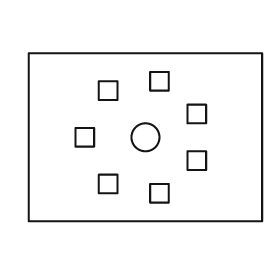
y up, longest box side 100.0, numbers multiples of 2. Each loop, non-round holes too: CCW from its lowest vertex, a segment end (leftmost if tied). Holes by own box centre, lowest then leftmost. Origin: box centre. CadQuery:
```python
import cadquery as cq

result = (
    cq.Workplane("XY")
    .moveTo(-50.0, -36.0)
    .lineTo(50.0, -36.0)
    .lineTo(50.0, 36.0)
    .lineTo(-50.0, 36.0)
    .close()
    .moveTo(2.0, -28.0)
    .lineTo(10.0, -28.0)
    .lineTo(10.0, -20.0)
    .lineTo(2.0, -20.0)
    .close()
    .moveTo(-20.0, -24.0)
    .lineTo(-12.0, -24.0)
    .lineTo(-12.0, -16.0)
    .lineTo(-20.0, -16.0)
    .close()
    .moveTo(18.0, -14.0)
    .lineTo(26.0, -14.0)
    .lineTo(26.0, -6.0)
    .lineTo(18.0, -6.0)
    .close()
    .moveTo(-30.0, -4.0)
    .lineTo(-22.0, -4.0)
    .lineTo(-22.0, 4.0)
    .lineTo(-30.0, 4.0)
    .close()
    .moveTo(0.0, 0.0)
    .circle(6.0)
    .moveTo(18.0, 6.0)
    .lineTo(26.0, 6.0)
    .lineTo(26.0, 14.0)
    .lineTo(18.0, 14.0)
    .close()
    .moveTo(-20.0, 16.0)
    .lineTo(-12.0, 16.0)
    .lineTo(-12.0, 24.0)
    .lineTo(-20.0, 24.0)
    .close()
    .moveTo(2.0, 20.0)
    .lineTo(10.0, 20.0)
    .lineTo(10.0, 28.0)
    .lineTo(2.0, 28.0)
    .close()
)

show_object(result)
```